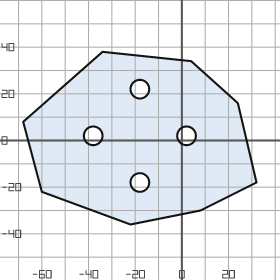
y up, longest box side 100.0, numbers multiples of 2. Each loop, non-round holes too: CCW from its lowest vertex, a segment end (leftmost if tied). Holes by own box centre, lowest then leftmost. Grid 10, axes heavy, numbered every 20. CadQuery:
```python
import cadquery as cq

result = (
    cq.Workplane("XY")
    .moveTo(-22.0, -36.0)
    .lineTo(8.0, -30.0)
    .lineTo(32.0, -18.0)
    .lineTo(24.0, 16.0)
    .lineTo(4.0, 34.0)
    .lineTo(-34.0, 38.0)
    .lineTo(-68.0, 8.0)
    .lineTo(-60.0, -22.0)
    .close()
    .moveTo(-18.0, -18.0)
    .circle(4.0)
    .moveTo(-38.0, 2.0)
    .circle(4.0)
    .moveTo(2.0, 2.0)
    .circle(4.0)
    .moveTo(-18.0, 22.0)
    .circle(4.0)
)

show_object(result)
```